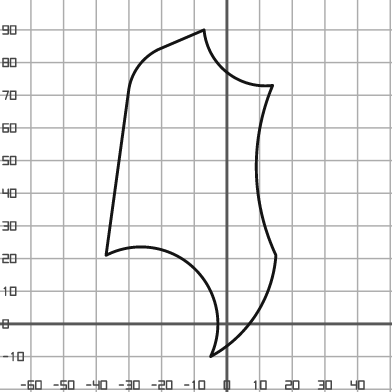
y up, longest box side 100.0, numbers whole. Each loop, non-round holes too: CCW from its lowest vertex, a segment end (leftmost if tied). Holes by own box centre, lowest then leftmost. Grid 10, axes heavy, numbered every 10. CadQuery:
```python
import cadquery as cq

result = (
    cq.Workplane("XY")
    .moveTo(-5.0, -10.0)
    .threePointArc((9.0, 3.0), (15.0, 21.0))
    .threePointArc((9.0, 47.0), (14.0, 73.0))
    .threePointArc((0.0, 77.0), (-7.0, 90.0))
    .lineTo(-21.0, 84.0)
    .threePointArc((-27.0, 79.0), (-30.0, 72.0))
    .lineTo(-37.0, 21.0)
    .threePointArc((-10.0, 17.0), (-5.0, -10.0))
    .close()
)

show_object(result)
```